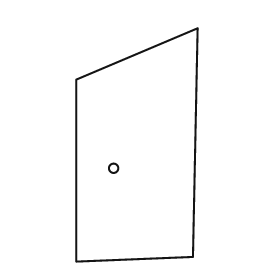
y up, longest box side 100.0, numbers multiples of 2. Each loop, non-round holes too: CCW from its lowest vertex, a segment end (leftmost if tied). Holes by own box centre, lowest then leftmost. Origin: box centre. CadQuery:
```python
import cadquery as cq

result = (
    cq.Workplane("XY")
    .moveTo(-26.0, -50.0)
    .lineTo(24.0, -48.0)
    .lineTo(26.0, 50.0)
    .lineTo(-26.0, 28.0)
    .close()
    .moveTo(-10.0, -10.0)
    .circle(2.0)
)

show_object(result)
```